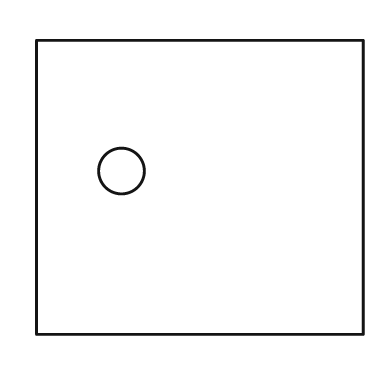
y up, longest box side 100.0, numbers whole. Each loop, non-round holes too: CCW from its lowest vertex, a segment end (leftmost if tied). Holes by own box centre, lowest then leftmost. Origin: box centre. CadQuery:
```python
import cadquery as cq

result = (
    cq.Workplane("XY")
    .moveTo(-50.0, -45.0)
    .lineTo(50.0, -45.0)
    .lineTo(50.0, 45.0)
    .lineTo(-50.0, 45.0)
    .close()
    .moveTo(-24.0, 5.0)
    .circle(7.0)
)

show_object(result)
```